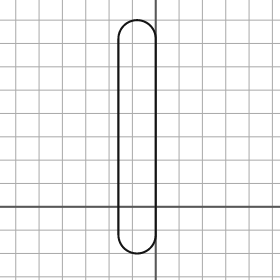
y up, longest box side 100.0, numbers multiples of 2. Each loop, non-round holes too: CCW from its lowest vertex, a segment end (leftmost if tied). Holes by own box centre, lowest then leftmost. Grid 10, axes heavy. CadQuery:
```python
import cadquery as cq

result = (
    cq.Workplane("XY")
    .moveTo(-16.0, -12.0)
    .threePointArc((-8.0, -20.0), (0.0, -12.0))
    .lineTo(0.0, 72.0)
    .threePointArc((-8.0, 80.0), (-16.0, 72.0))
    .close()
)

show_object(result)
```